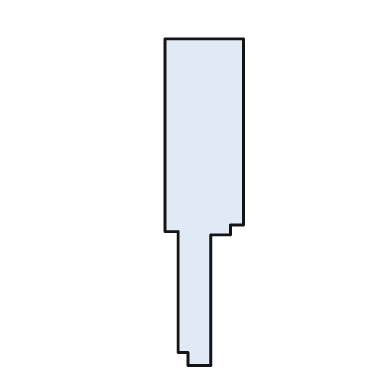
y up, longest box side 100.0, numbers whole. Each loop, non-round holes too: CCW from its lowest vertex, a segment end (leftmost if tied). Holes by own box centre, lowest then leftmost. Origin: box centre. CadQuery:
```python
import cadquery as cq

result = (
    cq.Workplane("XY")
    .moveTo(-5.0, -50.0)
    .lineTo(2.0, -50.0)
    .lineTo(2.0, -10.0)
    .lineTo(8.0, -10.0)
    .lineTo(8.0, -7.0)
    .lineTo(12.0, -7.0)
    .lineTo(12.0, 50.0)
    .lineTo(-12.0, 50.0)
    .lineTo(-12.0, -9.0)
    .lineTo(-8.0, -9.0)
    .lineTo(-8.0, -46.0)
    .lineTo(-5.0, -46.0)
    .close()
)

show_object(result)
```